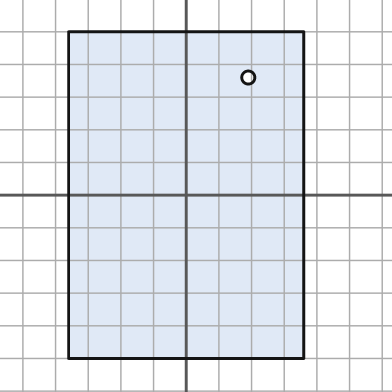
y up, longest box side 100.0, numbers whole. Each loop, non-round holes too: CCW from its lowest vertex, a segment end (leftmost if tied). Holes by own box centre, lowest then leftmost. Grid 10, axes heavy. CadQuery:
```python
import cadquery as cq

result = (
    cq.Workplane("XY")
    .moveTo(-36.0, -50.0)
    .lineTo(36.0, -50.0)
    .lineTo(36.0, 50.0)
    .lineTo(-36.0, 50.0)
    .close()
    .moveTo(19.0, 36.0)
    .circle(2.0)
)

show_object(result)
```